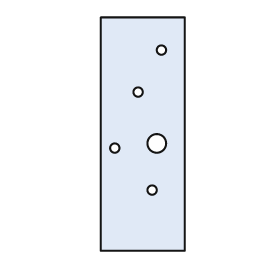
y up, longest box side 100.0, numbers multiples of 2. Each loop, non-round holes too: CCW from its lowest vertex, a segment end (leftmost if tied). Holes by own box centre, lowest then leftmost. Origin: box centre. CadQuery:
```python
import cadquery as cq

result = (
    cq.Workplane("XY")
    .moveTo(-18.0, -50.0)
    .lineTo(18.0, -50.0)
    .lineTo(18.0, 50.0)
    .lineTo(-18.0, 50.0)
    .close()
    .moveTo(4.0, -24.0)
    .circle(2.0)
    .moveTo(-12.0, -6.0)
    .circle(2.0)
    .moveTo(6.0, -4.0)
    .circle(4.0)
    .moveTo(-2.0, 18.0)
    .circle(2.0)
    .moveTo(8.0, 36.0)
    .circle(2.0)
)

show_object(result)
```